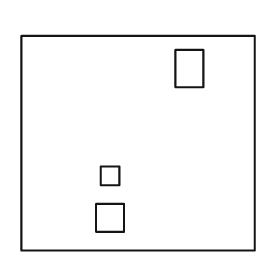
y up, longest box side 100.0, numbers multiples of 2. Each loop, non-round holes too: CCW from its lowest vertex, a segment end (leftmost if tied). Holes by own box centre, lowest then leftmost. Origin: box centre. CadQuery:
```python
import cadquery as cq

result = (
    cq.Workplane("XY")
    .moveTo(-50.0, -46.0)
    .lineTo(50.0, -46.0)
    .lineTo(50.0, 46.0)
    .lineTo(-50.0, 46.0)
    .close()
    .moveTo(-18.0, -38.0)
    .lineTo(-6.0, -38.0)
    .lineTo(-6.0, -26.0)
    .lineTo(-18.0, -26.0)
    .close()
    .moveTo(-16.0, -18.0)
    .lineTo(-8.0, -18.0)
    .lineTo(-8.0, -10.0)
    .lineTo(-16.0, -10.0)
    .close()
    .moveTo(16.0, 24.0)
    .lineTo(28.0, 24.0)
    .lineTo(28.0, 40.0)
    .lineTo(16.0, 40.0)
    .close()
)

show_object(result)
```